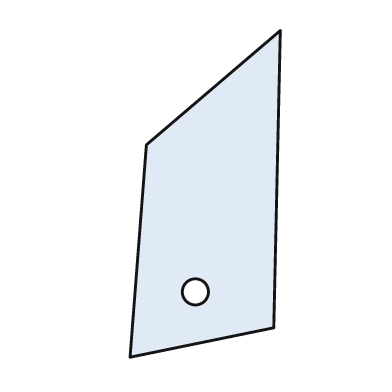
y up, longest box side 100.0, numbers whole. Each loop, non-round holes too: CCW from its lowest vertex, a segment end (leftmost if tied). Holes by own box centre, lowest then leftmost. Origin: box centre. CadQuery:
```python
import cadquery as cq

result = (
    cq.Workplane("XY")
    .moveTo(-23.0, -50.0)
    .lineTo(21.0, -41.0)
    .lineTo(23.0, 50.0)
    .lineTo(-18.0, 15.0)
    .close()
    .moveTo(-3.0, -30.0)
    .circle(4.0)
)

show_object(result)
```